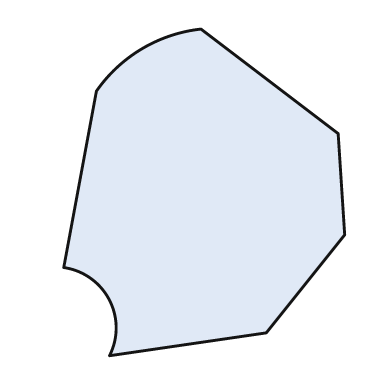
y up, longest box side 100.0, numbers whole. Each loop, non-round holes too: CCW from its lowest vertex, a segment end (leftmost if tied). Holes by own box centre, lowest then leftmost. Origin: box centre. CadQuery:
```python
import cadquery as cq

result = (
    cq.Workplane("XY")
    .moveTo(-29.0, -50.0)
    .lineTo(19.0, -43.0)
    .lineTo(43.0, -13.0)
    .lineTo(41.0, 18.0)
    .lineTo(-1.0, 50.0)
    .threePointArc((-19.0, 44.0), (-33.0, 31.0))
    .lineTo(-43.0, -23.0)
    .threePointArc((-29.0, -33.0), (-29.0, -50.0))
    .close()
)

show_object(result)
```